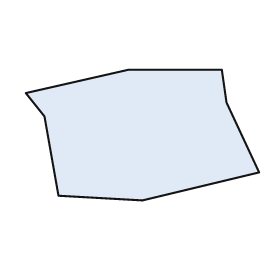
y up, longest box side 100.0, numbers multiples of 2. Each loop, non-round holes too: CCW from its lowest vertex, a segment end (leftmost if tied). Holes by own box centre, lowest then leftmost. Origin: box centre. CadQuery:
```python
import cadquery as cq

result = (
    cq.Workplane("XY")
    .moveTo(0.0, -28.0)
    .lineTo(50.0, -16.0)
    .lineTo(36.0, 14.0)
    .lineTo(34.0, 28.0)
    .lineTo(-6.0, 28.0)
    .lineTo(-50.0, 18.0)
    .lineTo(-42.0, 8.0)
    .lineTo(-36.0, -26.0)
    .close()
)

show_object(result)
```